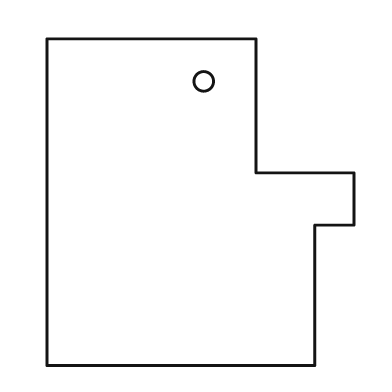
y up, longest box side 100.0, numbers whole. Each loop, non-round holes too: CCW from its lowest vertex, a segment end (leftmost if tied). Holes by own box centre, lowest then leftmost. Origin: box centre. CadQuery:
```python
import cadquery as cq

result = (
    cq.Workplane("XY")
    .moveTo(-47.0, -50.0)
    .lineTo(35.0, -50.0)
    .lineTo(35.0, -7.0)
    .lineTo(47.0, -7.0)
    .lineTo(47.0, 9.0)
    .lineTo(17.0, 9.0)
    .lineTo(17.0, 50.0)
    .lineTo(-47.0, 50.0)
    .close()
    .moveTo(1.0, 37.0)
    .circle(3.0)
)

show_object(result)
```